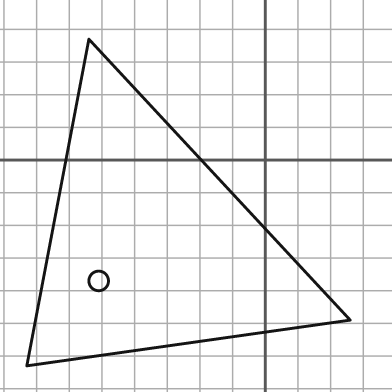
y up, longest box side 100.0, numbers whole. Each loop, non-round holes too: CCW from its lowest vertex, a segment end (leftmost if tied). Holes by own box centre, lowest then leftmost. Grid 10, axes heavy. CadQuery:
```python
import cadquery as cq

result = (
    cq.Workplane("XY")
    .moveTo(-73.0, -63.0)
    .lineTo(26.0, -49.0)
    .lineTo(-54.0, 37.0)
    .close()
    .moveTo(-51.0, -37.0)
    .circle(3.0)
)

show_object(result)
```